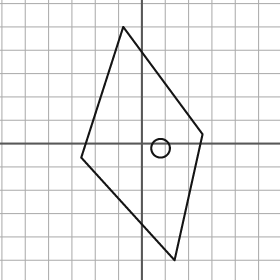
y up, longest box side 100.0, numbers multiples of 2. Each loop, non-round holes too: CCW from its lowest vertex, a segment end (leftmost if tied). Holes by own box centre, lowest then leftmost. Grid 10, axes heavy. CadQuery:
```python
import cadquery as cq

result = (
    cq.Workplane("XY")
    .moveTo(14.0, -50.0)
    .lineTo(26.0, 4.0)
    .lineTo(-8.0, 50.0)
    .lineTo(-26.0, -6.0)
    .close()
    .moveTo(8.0, -2.0)
    .circle(4.0)
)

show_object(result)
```